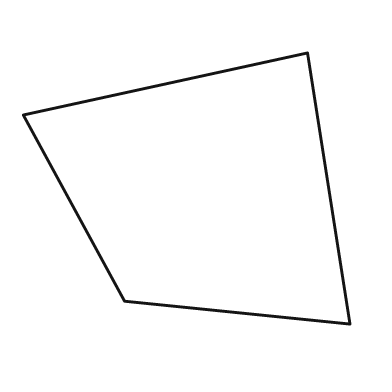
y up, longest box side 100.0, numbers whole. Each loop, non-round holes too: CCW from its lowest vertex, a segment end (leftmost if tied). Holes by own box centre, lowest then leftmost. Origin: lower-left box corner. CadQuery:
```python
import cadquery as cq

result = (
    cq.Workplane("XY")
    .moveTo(100.0, 0.0)
    .lineTo(87.0, 83.0)
    .lineTo(0.0, 64.0)
    .lineTo(31.0, 7.0)
    .close()
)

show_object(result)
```